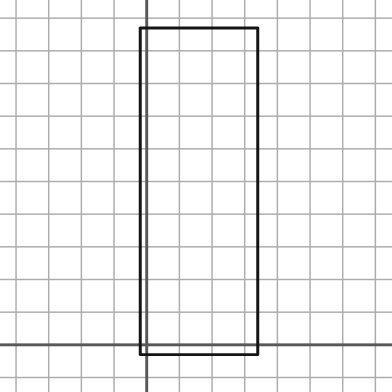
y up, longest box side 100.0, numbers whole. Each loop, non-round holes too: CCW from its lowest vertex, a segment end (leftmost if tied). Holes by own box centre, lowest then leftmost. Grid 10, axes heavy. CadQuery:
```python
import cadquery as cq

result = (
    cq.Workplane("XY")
    .moveTo(-2.0, -3.0)
    .lineTo(34.0, -3.0)
    .lineTo(34.0, 97.0)
    .lineTo(-2.0, 97.0)
    .close()
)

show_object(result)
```